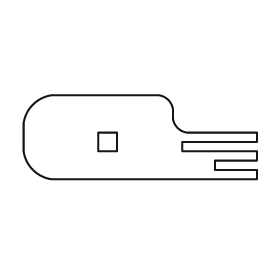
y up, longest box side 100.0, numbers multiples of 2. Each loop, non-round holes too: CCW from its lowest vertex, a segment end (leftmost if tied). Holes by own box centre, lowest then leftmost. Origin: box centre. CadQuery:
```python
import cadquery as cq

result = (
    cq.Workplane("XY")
    .moveTo(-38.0, -18.0)
    .lineTo(50.0, -18.0)
    .lineTo(50.0, -14.0)
    .lineTo(32.0, -14.0)
    .lineTo(32.0, -10.0)
    .lineTo(50.0, -10.0)
    .lineTo(50.0, -6.0)
    .lineTo(18.0, -6.0)
    .lineTo(18.0, -2.0)
    .lineTo(50.0, -2.0)
    .lineTo(50.0, 2.0)
    .lineTo(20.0, 2.0)
    .threePointArc((16.0, 4.0), (14.0, 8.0))
    .lineTo(14.0, 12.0)
    .threePointArc((12.0, 16.0), (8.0, 18.0))
    .lineTo(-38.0, 18.0)
    .threePointArc((-46.0, 14.0), (-50.0, 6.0))
    .lineTo(-50.0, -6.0)
    .threePointArc((-46.0, -14.0), (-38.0, -18.0))
    .close()
    .moveTo(-18.0, -6.0)
    .lineTo(-10.0, -6.0)
    .lineTo(-10.0, 2.0)
    .lineTo(-18.0, 2.0)
    .close()
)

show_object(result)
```